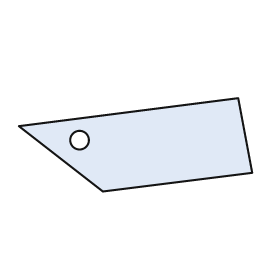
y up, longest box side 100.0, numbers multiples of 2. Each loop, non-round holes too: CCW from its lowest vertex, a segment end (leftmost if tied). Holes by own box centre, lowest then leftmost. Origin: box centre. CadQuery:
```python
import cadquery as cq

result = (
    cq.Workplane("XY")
    .moveTo(-14.0, -20.0)
    .lineTo(50.0, -12.0)
    .lineTo(44.0, 20.0)
    .lineTo(-50.0, 8.0)
    .close()
    .moveTo(-24.0, 2.0)
    .circle(4.0)
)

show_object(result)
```